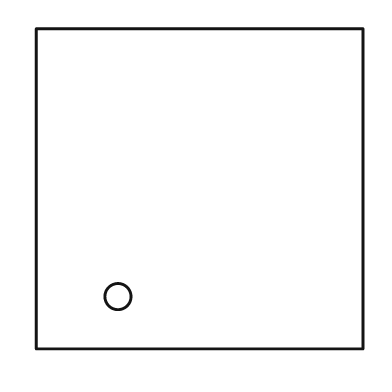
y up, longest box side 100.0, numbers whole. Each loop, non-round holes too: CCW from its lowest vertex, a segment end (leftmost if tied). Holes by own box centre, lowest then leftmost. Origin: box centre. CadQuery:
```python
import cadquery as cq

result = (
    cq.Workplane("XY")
    .moveTo(-50.0, -49.0)
    .lineTo(50.0, -49.0)
    .lineTo(50.0, 49.0)
    .lineTo(-50.0, 49.0)
    .close()
    .moveTo(-25.0, -33.0)
    .circle(4.0)
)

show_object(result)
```